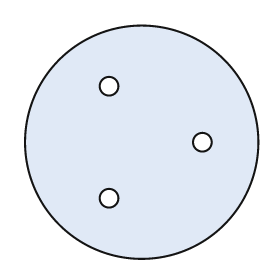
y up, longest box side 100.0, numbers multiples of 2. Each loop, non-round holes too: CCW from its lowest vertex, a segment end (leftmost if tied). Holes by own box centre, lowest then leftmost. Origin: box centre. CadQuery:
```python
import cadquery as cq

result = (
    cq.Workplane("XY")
    .moveTo(0.0, 0.0)
    .circle(50.0)
    .moveTo(-14.0, -24.0)
    .circle(4.0)
    .moveTo(26.0, 0.0)
    .circle(4.0)
    .moveTo(-14.0, 24.0)
    .circle(4.0)
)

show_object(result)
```